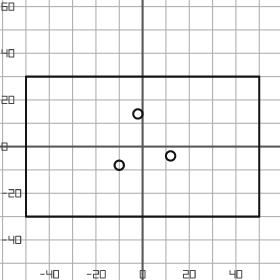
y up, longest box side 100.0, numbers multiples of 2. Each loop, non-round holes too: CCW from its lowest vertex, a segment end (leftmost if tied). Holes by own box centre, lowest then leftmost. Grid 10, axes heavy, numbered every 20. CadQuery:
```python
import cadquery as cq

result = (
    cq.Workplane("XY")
    .moveTo(-50.0, -30.0)
    .lineTo(50.0, -30.0)
    .lineTo(50.0, 30.0)
    .lineTo(-50.0, 30.0)
    .close()
    .moveTo(-10.0, -8.0)
    .circle(2.0)
    .moveTo(12.0, -4.0)
    .circle(2.0)
    .moveTo(-2.0, 14.0)
    .circle(2.0)
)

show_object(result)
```